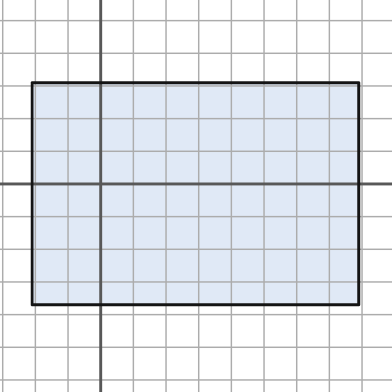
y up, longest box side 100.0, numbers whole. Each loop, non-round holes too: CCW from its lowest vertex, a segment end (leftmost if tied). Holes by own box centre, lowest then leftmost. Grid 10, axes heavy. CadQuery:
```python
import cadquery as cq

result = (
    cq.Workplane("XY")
    .moveTo(-21.0, -37.0)
    .lineTo(79.0, -37.0)
    .lineTo(79.0, 31.0)
    .lineTo(-21.0, 31.0)
    .close()
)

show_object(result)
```